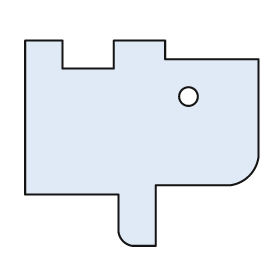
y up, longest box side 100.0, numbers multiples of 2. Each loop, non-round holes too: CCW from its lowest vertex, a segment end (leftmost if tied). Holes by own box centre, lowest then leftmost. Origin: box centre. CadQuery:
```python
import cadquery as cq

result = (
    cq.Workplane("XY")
    .moveTo(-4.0, -44.0)
    .lineTo(6.0, -44.0)
    .lineTo(6.0, -18.0)
    .lineTo(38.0, -18.0)
    .threePointArc((46.0, -14.0), (50.0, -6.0))
    .lineTo(50.0, 36.0)
    .lineTo(10.0, 36.0)
    .lineTo(10.0, 44.0)
    .lineTo(-12.0, 44.0)
    .lineTo(-12.0, 32.0)
    .lineTo(-34.0, 32.0)
    .lineTo(-34.0, 44.0)
    .lineTo(-50.0, 44.0)
    .lineTo(-50.0, -22.0)
    .lineTo(-10.0, -22.0)
    .lineTo(-10.0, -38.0)
    .threePointArc((-8.0, -42.0), (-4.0, -44.0))
    .close()
    .moveTo(20.0, 20.0)
    .circle(4.0)
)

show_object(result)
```